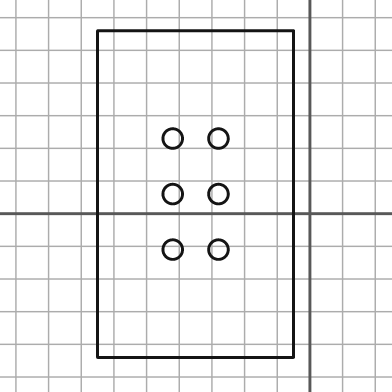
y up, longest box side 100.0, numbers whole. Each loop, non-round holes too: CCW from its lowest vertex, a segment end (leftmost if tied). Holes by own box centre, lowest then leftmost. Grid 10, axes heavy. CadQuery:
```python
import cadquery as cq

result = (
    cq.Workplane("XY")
    .moveTo(-65.0, -44.0)
    .lineTo(-5.0, -44.0)
    .lineTo(-5.0, 56.0)
    .lineTo(-65.0, 56.0)
    .close()
    .moveTo(-42.0, -11.0)
    .circle(3.0)
    .moveTo(-28.0, -11.0)
    .circle(3.0)
    .moveTo(-42.0, 6.0)
    .circle(3.0)
    .moveTo(-28.0, 6.0)
    .circle(3.0)
    .moveTo(-42.0, 23.0)
    .circle(3.0)
    .moveTo(-28.0, 23.0)
    .circle(3.0)
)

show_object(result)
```